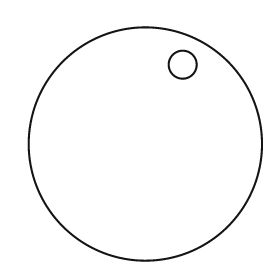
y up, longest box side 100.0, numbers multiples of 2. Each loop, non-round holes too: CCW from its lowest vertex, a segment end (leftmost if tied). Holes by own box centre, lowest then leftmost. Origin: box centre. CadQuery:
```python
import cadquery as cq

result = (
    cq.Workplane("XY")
    .moveTo(0.0, 0.0)
    .circle(50.0)
    .moveTo(16.0, 34.0)
    .circle(6.0)
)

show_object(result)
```